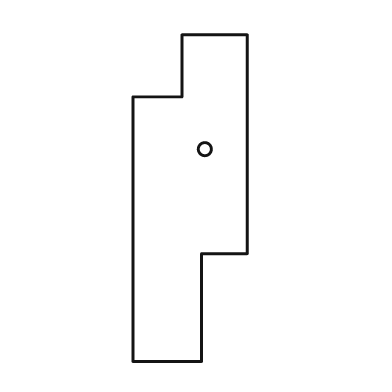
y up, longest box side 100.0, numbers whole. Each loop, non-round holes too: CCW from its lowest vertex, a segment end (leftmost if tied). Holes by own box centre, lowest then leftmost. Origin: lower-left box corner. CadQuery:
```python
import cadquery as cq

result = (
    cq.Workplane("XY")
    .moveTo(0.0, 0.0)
    .lineTo(21.0, 0.0)
    .lineTo(21.0, 33.0)
    .lineTo(35.0, 33.0)
    .lineTo(35.0, 100.0)
    .lineTo(15.0, 100.0)
    .lineTo(15.0, 81.0)
    .lineTo(0.0, 81.0)
    .close()
    .moveTo(22.0, 65.0)
    .circle(2.0)
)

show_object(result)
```